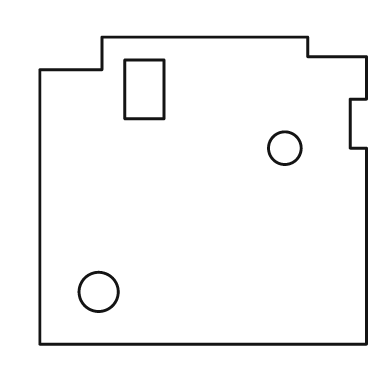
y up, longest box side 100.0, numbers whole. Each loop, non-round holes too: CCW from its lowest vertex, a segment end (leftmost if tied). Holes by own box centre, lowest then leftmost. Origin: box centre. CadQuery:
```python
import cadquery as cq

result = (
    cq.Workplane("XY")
    .moveTo(-50.0, -47.0)
    .lineTo(50.0, -47.0)
    .lineTo(50.0, 13.0)
    .lineTo(45.0, 13.0)
    .lineTo(45.0, 28.0)
    .lineTo(50.0, 28.0)
    .lineTo(50.0, 41.0)
    .lineTo(32.0, 41.0)
    .lineTo(32.0, 47.0)
    .lineTo(-31.0, 47.0)
    .lineTo(-31.0, 37.0)
    .lineTo(-50.0, 37.0)
    .close()
    .moveTo(-32.0, -31.0)
    .circle(6.0)
    .moveTo(25.0, 13.0)
    .circle(5.0)
    .moveTo(-24.0, 22.0)
    .lineTo(-12.0, 22.0)
    .lineTo(-12.0, 40.0)
    .lineTo(-24.0, 40.0)
    .close()
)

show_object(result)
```